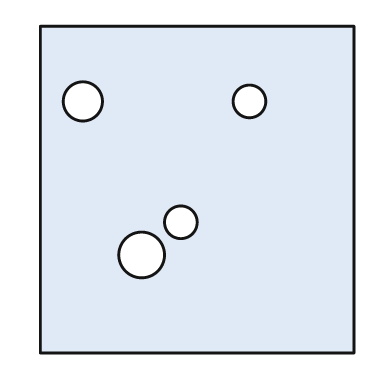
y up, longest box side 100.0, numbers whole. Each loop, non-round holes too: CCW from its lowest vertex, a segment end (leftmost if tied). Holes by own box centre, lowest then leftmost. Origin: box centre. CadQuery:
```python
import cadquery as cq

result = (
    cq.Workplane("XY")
    .moveTo(-48.0, -50.0)
    .lineTo(48.0, -50.0)
    .lineTo(48.0, 50.0)
    .lineTo(-48.0, 50.0)
    .close()
    .moveTo(-17.0, -20.0)
    .circle(7.0)
    .moveTo(-5.0, -10.0)
    .circle(5.0)
    .moveTo(-35.0, 27.0)
    .circle(6.0)
    .moveTo(16.0, 27.0)
    .circle(5.0)
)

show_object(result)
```